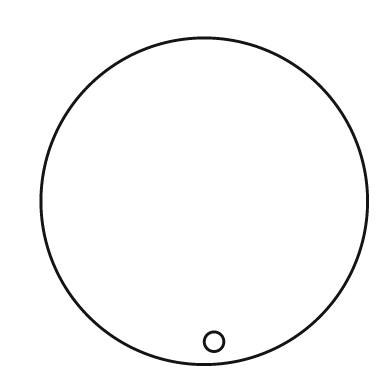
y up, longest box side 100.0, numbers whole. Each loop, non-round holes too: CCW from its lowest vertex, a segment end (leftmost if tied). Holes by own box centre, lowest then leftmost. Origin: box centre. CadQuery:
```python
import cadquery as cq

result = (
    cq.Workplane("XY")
    .moveTo(0.0, 0.0)
    .circle(50.0)
    .moveTo(3.0, -43.0)
    .circle(3.0)
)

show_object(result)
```